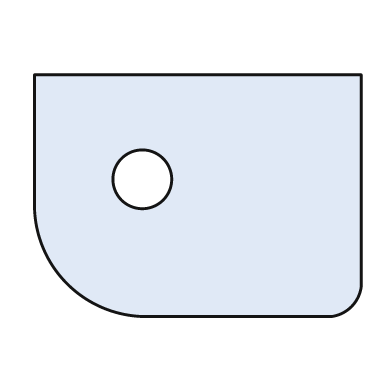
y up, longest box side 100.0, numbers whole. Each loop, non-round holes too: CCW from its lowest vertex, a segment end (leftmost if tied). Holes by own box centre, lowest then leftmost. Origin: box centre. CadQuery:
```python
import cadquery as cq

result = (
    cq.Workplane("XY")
    .moveTo(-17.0, -37.0)
    .lineTo(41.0, -37.0)
    .threePointArc((47.0, -34.0), (50.0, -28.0))
    .lineTo(50.0, 37.0)
    .lineTo(-50.0, 37.0)
    .lineTo(-50.0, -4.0)
    .threePointArc((-40.0, -27.0), (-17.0, -37.0))
    .close()
    .moveTo(-17.0, 5.0)
    .circle(9.0)
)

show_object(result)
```